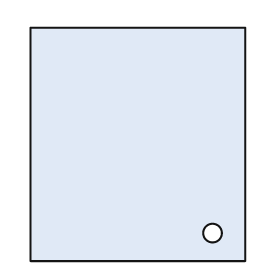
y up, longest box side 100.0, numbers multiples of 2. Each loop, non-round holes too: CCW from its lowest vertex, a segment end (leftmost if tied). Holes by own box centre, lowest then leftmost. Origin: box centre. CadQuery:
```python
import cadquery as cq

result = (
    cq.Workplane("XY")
    .moveTo(-46.0, -50.0)
    .lineTo(46.0, -50.0)
    .lineTo(46.0, 50.0)
    .lineTo(-46.0, 50.0)
    .close()
    .moveTo(32.0, -38.0)
    .circle(4.0)
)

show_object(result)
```